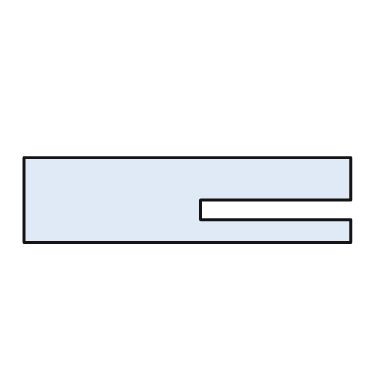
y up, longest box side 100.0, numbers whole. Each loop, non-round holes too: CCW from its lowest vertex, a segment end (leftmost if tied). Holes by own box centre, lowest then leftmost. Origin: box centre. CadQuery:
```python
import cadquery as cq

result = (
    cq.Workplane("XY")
    .moveTo(-50.0, -13.0)
    .lineTo(50.0, -13.0)
    .lineTo(50.0, -6.0)
    .lineTo(4.0, -6.0)
    .lineTo(4.0, 0.0)
    .lineTo(50.0, 0.0)
    .lineTo(50.0, 13.0)
    .lineTo(-50.0, 13.0)
    .close()
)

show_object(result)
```